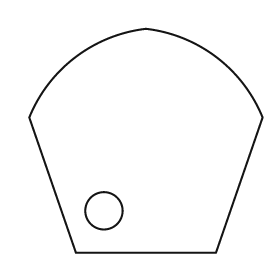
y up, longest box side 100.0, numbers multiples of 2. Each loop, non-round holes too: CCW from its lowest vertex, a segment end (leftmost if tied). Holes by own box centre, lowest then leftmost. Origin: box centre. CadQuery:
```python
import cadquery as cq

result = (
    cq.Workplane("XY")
    .moveTo(-30.0, -48.0)
    .lineTo(30.0, -48.0)
    .lineTo(50.0, 10.0)
    .threePointArc((30.0, 36.0), (0.0, 48.0))
    .threePointArc((-30.0, 36.0), (-50.0, 10.0))
    .close()
    .moveTo(-18.0, -30.0)
    .circle(8.0)
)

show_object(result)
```